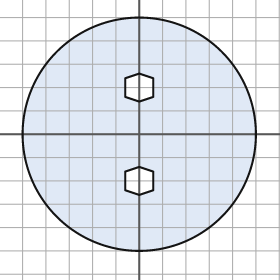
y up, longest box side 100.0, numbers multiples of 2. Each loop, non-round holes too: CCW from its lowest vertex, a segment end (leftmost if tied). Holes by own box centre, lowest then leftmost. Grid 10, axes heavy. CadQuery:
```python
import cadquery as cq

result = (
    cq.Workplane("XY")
    .moveTo(0.0, 0.0)
    .circle(50.0)
    .moveTo(0.0, -26.0)
    .lineTo(6.0, -24.0)
    .lineTo(6.0, -16.0)
    .lineTo(0.0, -14.0)
    .lineTo(-6.0, -16.0)
    .lineTo(-6.0, -24.0)
    .close()
    .moveTo(0.0, 14.0)
    .lineTo(6.0, 16.0)
    .lineTo(6.0, 24.0)
    .lineTo(0.0, 26.0)
    .lineTo(-6.0, 24.0)
    .lineTo(-6.0, 16.0)
    .close()
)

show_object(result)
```